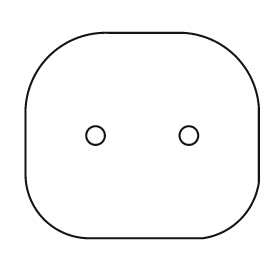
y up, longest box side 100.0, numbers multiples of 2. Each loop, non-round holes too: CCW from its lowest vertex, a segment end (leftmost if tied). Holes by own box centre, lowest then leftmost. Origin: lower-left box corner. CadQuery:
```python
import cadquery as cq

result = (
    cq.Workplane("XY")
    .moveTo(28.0, 0.0)
    .lineTo(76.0, 0.0)
    .threePointArc((92.0, 8.0), (100.0, 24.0))
    .lineTo(100.0, 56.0)
    .threePointArc((90.0, 78.0), (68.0, 88.0))
    .lineTo(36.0, 88.0)
    .threePointArc((10.0, 78.0), (0.0, 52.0))
    .lineTo(0.0, 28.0)
    .threePointArc((8.0, 8.0), (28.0, 0.0))
    .close()
    .moveTo(30.0, 44.0)
    .circle(4.0)
    .moveTo(70.0, 44.0)
    .circle(4.0)
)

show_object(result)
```